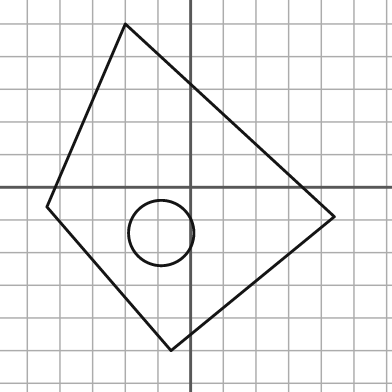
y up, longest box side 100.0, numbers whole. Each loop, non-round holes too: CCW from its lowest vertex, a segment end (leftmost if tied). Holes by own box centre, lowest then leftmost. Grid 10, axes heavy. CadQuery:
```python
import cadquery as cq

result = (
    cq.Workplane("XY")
    .moveTo(-6.0, -50.0)
    .lineTo(44.0, -9.0)
    .lineTo(-20.0, 50.0)
    .lineTo(-44.0, -6.0)
    .close()
    .moveTo(-9.0, -14.0)
    .circle(10.0)
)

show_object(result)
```